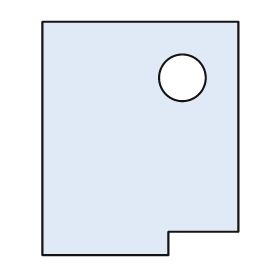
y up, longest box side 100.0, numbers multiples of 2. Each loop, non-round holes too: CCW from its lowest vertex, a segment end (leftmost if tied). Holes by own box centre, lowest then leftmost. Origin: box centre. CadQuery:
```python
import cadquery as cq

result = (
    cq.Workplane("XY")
    .moveTo(-42.0, -50.0)
    .lineTo(12.0, -50.0)
    .lineTo(12.0, -40.0)
    .lineTo(42.0, -40.0)
    .lineTo(42.0, 50.0)
    .lineTo(-42.0, 50.0)
    .close()
    .moveTo(18.0, 26.0)
    .circle(10.0)
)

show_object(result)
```